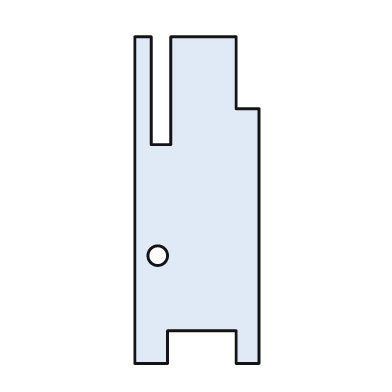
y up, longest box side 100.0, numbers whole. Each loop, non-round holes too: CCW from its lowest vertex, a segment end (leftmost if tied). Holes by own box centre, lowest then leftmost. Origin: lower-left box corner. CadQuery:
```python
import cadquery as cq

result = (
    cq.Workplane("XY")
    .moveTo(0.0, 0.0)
    .lineTo(10.0, 0.0)
    .lineTo(10.0, 10.0)
    .lineTo(31.0, 10.0)
    .lineTo(31.0, 0.0)
    .lineTo(38.0, 0.0)
    .lineTo(38.0, 78.0)
    .lineTo(31.0, 78.0)
    .lineTo(31.0, 100.0)
    .lineTo(11.0, 100.0)
    .lineTo(11.0, 67.0)
    .lineTo(5.0, 67.0)
    .lineTo(5.0, 100.0)
    .lineTo(0.0, 100.0)
    .close()
    .moveTo(7.0, 33.0)
    .circle(3.0)
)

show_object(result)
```